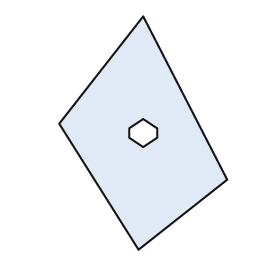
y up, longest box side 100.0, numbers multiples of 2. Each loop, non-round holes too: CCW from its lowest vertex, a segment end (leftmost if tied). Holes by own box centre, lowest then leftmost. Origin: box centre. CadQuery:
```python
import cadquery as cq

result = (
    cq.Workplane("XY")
    .moveTo(-2.0, -50.0)
    .lineTo(36.0, -20.0)
    .lineTo(0.0, 50.0)
    .lineTo(-36.0, 4.0)
    .close()
    .moveTo(0.0, -6.0)
    .lineTo(6.0, -2.0)
    .lineTo(6.0, 2.0)
    .lineTo(0.0, 6.0)
    .lineTo(-6.0, 2.0)
    .lineTo(-6.0, -2.0)
    .close()
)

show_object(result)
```